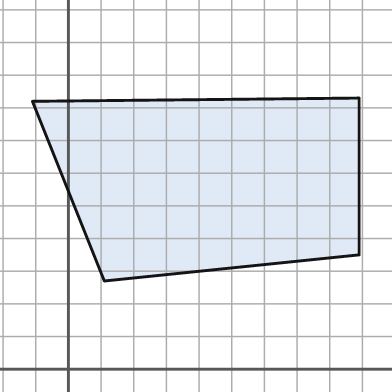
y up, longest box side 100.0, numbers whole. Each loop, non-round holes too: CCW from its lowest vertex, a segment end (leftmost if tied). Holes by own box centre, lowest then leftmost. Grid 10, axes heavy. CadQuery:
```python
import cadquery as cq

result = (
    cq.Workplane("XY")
    .moveTo(11.0, 27.0)
    .lineTo(89.0, 35.0)
    .lineTo(89.0, 83.0)
    .lineTo(-11.0, 82.0)
    .close()
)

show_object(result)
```